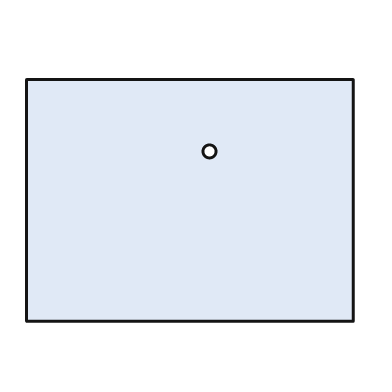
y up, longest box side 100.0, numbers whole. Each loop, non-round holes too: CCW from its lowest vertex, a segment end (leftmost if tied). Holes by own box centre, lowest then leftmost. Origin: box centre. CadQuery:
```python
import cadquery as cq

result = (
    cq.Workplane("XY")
    .moveTo(-50.0, -37.0)
    .lineTo(50.0, -37.0)
    .lineTo(50.0, 37.0)
    .lineTo(-50.0, 37.0)
    .close()
    .moveTo(6.0, 15.0)
    .circle(2.0)
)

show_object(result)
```